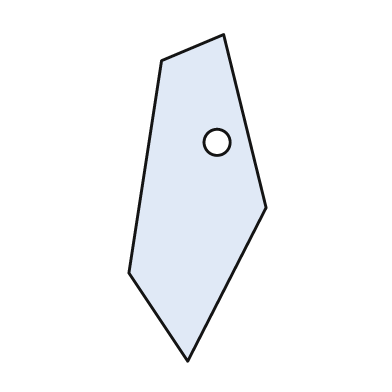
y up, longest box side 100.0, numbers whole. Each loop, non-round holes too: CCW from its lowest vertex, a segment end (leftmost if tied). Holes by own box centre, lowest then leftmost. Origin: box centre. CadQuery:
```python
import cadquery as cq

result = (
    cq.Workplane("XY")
    .moveTo(-3.0, -50.0)
    .lineTo(21.0, -3.0)
    .lineTo(8.0, 50.0)
    .lineTo(-11.0, 42.0)
    .lineTo(-21.0, -23.0)
    .close()
    .moveTo(6.0, 17.0)
    .circle(4.0)
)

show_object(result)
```